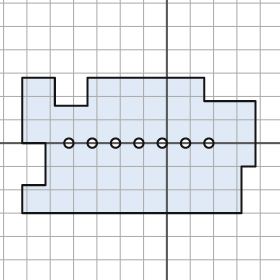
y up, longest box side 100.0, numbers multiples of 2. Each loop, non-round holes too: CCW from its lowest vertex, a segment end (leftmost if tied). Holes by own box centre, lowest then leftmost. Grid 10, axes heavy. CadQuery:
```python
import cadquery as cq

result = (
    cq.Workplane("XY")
    .moveTo(-62.0, -30.0)
    .lineTo(32.0, -30.0)
    .lineTo(32.0, -10.0)
    .lineTo(38.0, -10.0)
    .lineTo(38.0, 18.0)
    .lineTo(16.0, 18.0)
    .lineTo(16.0, 28.0)
    .lineTo(-34.0, 28.0)
    .lineTo(-34.0, 16.0)
    .lineTo(-48.0, 16.0)
    .lineTo(-48.0, 28.0)
    .lineTo(-62.0, 28.0)
    .lineTo(-62.0, 0.0)
    .lineTo(-52.0, 0.0)
    .lineTo(-52.0, -18.0)
    .lineTo(-62.0, -18.0)
    .close()
    .moveTo(-42.0, 0.0)
    .circle(2.0)
    .moveTo(-32.0, 0.0)
    .circle(2.0)
    .moveTo(-22.0, 0.0)
    .circle(2.0)
    .moveTo(-12.0, 0.0)
    .circle(2.0)
    .moveTo(-2.0, 0.0)
    .circle(2.0)
    .moveTo(8.0, 0.0)
    .circle(2.0)
    .moveTo(18.0, 0.0)
    .circle(2.0)
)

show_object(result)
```